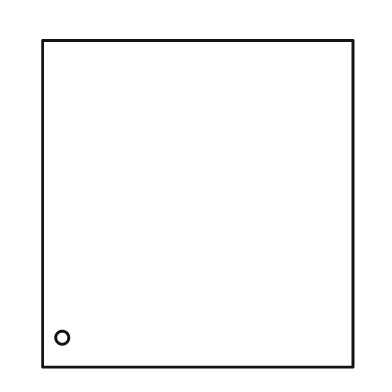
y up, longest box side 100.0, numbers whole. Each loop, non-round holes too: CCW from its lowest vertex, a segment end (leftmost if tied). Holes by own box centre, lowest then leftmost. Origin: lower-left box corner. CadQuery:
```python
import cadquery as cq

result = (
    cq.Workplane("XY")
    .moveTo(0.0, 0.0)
    .lineTo(95.0, 0.0)
    .lineTo(95.0, 100.0)
    .lineTo(0.0, 100.0)
    .close()
    .moveTo(6.0, 9.0)
    .circle(2.0)
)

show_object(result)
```